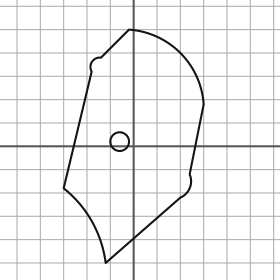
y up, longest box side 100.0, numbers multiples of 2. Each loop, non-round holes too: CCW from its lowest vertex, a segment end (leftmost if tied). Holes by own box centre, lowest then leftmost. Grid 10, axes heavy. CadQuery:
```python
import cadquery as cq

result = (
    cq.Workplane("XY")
    .moveTo(-12.0, -50.0)
    .lineTo(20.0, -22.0)
    .threePointArc((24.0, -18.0), (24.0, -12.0))
    .lineTo(30.0, 18.0)
    .threePointArc((20.0, 40.0), (-2.0, 50.0))
    .lineTo(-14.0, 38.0)
    .threePointArc((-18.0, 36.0), (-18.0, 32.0))
    .lineTo(-30.0, -18.0)
    .threePointArc((-18.0, -32.0), (-12.0, -50.0))
    .close()
    .moveTo(-6.0, 2.0)
    .circle(4.0)
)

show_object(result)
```